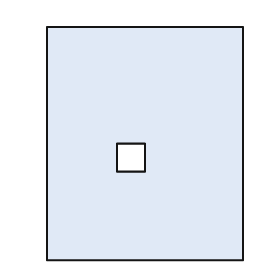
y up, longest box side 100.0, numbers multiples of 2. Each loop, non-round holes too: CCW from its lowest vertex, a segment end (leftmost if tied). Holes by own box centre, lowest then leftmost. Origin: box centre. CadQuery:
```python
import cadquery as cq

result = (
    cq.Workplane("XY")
    .moveTo(-42.0, -50.0)
    .lineTo(42.0, -50.0)
    .lineTo(42.0, 50.0)
    .lineTo(-42.0, 50.0)
    .close()
    .moveTo(-12.0, -12.0)
    .lineTo(0.0, -12.0)
    .lineTo(0.0, 0.0)
    .lineTo(-12.0, 0.0)
    .close()
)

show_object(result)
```